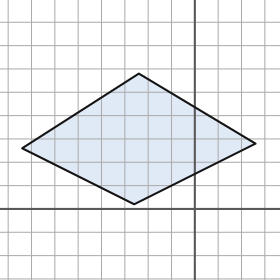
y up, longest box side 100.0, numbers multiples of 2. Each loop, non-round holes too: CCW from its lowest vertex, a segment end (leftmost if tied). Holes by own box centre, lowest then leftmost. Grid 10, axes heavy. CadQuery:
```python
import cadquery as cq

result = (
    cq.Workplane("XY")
    .moveTo(-26.0, 2.0)
    .lineTo(26.0, 28.0)
    .lineTo(-24.0, 58.0)
    .lineTo(-74.0, 26.0)
    .close()
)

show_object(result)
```